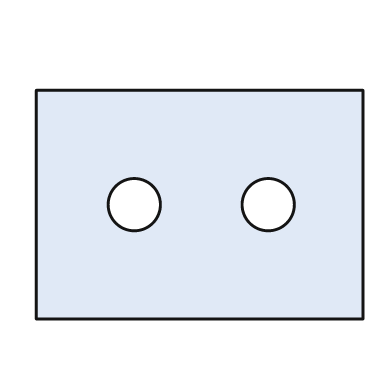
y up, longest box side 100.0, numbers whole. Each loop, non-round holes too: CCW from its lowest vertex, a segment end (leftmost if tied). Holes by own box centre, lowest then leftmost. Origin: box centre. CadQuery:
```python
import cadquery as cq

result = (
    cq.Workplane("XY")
    .moveTo(-50.0, -35.0)
    .lineTo(50.0, -35.0)
    .lineTo(50.0, 35.0)
    .lineTo(-50.0, 35.0)
    .close()
    .moveTo(-20.0, 0.0)
    .circle(8.0)
    .moveTo(21.0, 0.0)
    .circle(8.0)
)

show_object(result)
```